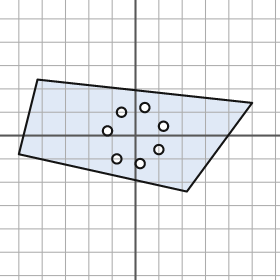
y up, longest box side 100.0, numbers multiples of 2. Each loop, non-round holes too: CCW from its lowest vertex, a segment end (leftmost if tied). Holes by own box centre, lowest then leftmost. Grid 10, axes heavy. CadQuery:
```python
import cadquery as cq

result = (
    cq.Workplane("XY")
    .moveTo(22.0, -24.0)
    .lineTo(50.0, 14.0)
    .lineTo(-42.0, 24.0)
    .lineTo(-50.0, -8.0)
    .close()
    .moveTo(2.0, -12.0)
    .circle(2.0)
    .moveTo(-8.0, -10.0)
    .circle(2.0)
    .moveTo(10.0, -6.0)
    .circle(2.0)
    .moveTo(-12.0, 2.0)
    .circle(2.0)
    .moveTo(12.0, 4.0)
    .circle(2.0)
    .moveTo(-6.0, 10.0)
    .circle(2.0)
    .moveTo(4.0, 12.0)
    .circle(2.0)
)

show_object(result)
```